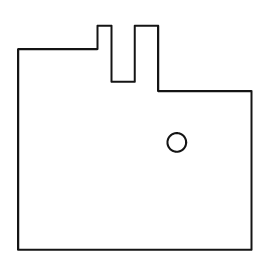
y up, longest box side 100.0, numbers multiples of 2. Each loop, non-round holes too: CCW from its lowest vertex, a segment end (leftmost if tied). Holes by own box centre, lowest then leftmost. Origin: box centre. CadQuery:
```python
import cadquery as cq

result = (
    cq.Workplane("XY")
    .moveTo(-50.0, -48.0)
    .lineTo(50.0, -48.0)
    .lineTo(50.0, 20.0)
    .lineTo(10.0, 20.0)
    .lineTo(10.0, 48.0)
    .lineTo(0.0, 48.0)
    .lineTo(0.0, 24.0)
    .lineTo(-10.0, 24.0)
    .lineTo(-10.0, 48.0)
    .lineTo(-16.0, 48.0)
    .lineTo(-16.0, 38.0)
    .lineTo(-50.0, 38.0)
    .close()
    .moveTo(18.0, -2.0)
    .circle(4.0)
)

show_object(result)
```